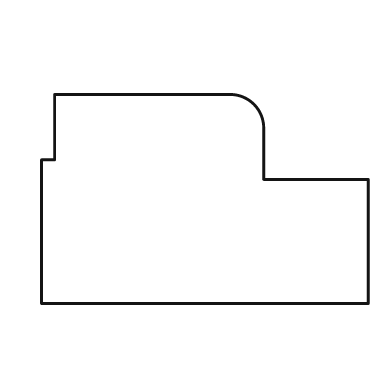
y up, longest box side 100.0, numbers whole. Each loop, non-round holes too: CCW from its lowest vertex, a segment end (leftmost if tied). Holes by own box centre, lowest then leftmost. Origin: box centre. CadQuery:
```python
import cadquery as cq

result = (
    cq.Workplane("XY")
    .moveTo(-50.0, -32.0)
    .lineTo(50.0, -32.0)
    .lineTo(50.0, 6.0)
    .lineTo(18.0, 6.0)
    .lineTo(18.0, 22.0)
    .threePointArc((15.0, 29.0), (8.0, 32.0))
    .lineTo(-46.0, 32.0)
    .lineTo(-46.0, 12.0)
    .lineTo(-50.0, 12.0)
    .close()
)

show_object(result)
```